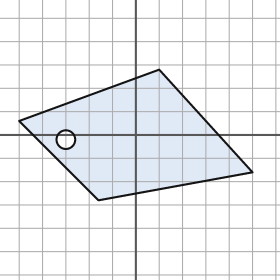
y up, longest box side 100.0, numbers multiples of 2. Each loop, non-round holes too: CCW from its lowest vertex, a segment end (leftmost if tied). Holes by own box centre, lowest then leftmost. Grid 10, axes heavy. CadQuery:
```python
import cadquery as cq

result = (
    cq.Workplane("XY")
    .moveTo(-16.0, -28.0)
    .lineTo(50.0, -16.0)
    .lineTo(10.0, 28.0)
    .lineTo(-50.0, 6.0)
    .close()
    .moveTo(-30.0, -2.0)
    .circle(4.0)
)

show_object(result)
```